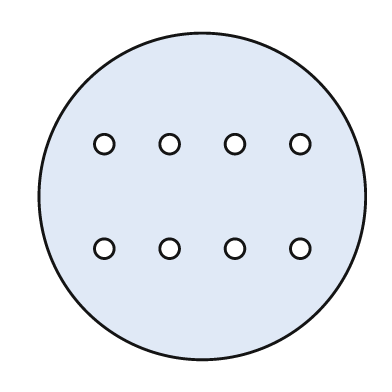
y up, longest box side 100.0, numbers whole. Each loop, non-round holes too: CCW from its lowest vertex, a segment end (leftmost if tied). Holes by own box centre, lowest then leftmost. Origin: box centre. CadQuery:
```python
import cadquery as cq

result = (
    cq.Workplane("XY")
    .moveTo(0.0, 0.0)
    .circle(50.0)
    .moveTo(-30.0, -16.0)
    .circle(3.0)
    .moveTo(-10.0, -16.0)
    .circle(3.0)
    .moveTo(10.0, -16.0)
    .circle(3.0)
    .moveTo(30.0, -16.0)
    .circle(3.0)
    .moveTo(-30.0, 16.0)
    .circle(3.0)
    .moveTo(-10.0, 16.0)
    .circle(3.0)
    .moveTo(10.0, 16.0)
    .circle(3.0)
    .moveTo(30.0, 16.0)
    .circle(3.0)
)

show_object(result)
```